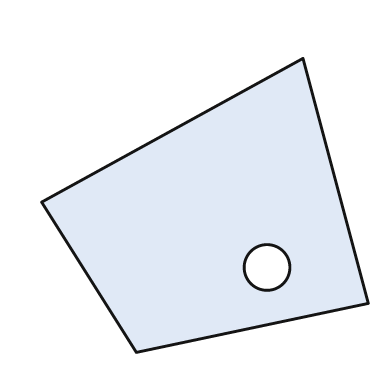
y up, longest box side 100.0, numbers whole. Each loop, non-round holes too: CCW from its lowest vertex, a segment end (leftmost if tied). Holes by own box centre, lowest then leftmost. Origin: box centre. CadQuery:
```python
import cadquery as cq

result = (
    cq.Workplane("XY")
    .moveTo(-21.0, -45.0)
    .lineTo(50.0, -30.0)
    .lineTo(30.0, 45.0)
    .lineTo(-50.0, 1.0)
    .close()
    .moveTo(19.0, -19.0)
    .circle(7.0)
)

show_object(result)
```